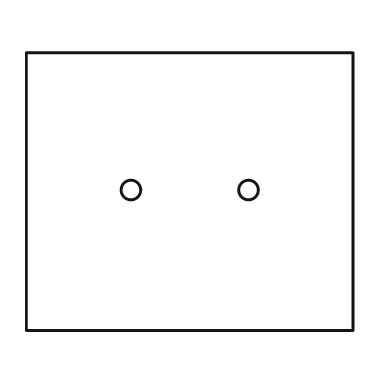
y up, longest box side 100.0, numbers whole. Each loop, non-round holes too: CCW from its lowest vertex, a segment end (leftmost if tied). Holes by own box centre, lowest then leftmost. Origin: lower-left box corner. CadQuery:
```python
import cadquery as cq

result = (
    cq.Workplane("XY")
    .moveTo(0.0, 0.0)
    .lineTo(100.0, 0.0)
    .lineTo(100.0, 85.0)
    .lineTo(0.0, 85.0)
    .close()
    .moveTo(32.0, 43.0)
    .circle(3.0)
    .moveTo(68.0, 43.0)
    .circle(3.0)
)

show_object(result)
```